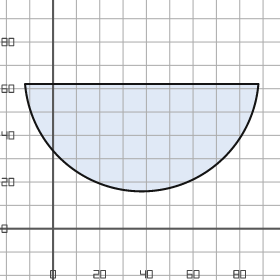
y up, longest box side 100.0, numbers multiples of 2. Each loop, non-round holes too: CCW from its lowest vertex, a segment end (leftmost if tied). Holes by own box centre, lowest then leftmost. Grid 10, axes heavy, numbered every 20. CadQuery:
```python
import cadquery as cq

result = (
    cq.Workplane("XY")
    .moveTo(-12.0, 62.0)
    .threePointArc((38.0, 16.0), (88.0, 62.0))
    .close()
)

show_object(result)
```